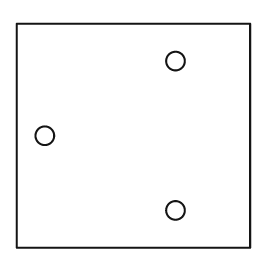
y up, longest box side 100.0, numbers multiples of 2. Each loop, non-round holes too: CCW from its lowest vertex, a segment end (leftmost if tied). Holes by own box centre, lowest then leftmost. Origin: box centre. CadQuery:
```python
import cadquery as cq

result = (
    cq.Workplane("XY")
    .moveTo(-50.0, -48.0)
    .lineTo(50.0, -48.0)
    .lineTo(50.0, 48.0)
    .lineTo(-50.0, 48.0)
    .close()
    .moveTo(18.0, -32.0)
    .circle(4.0)
    .moveTo(-38.0, 0.0)
    .circle(4.0)
    .moveTo(18.0, 32.0)
    .circle(4.0)
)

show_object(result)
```